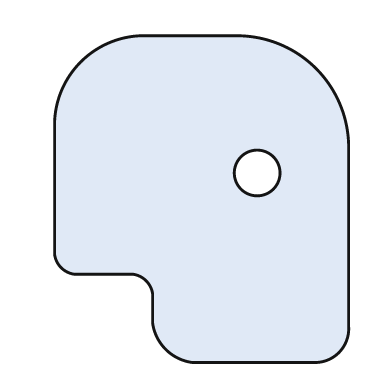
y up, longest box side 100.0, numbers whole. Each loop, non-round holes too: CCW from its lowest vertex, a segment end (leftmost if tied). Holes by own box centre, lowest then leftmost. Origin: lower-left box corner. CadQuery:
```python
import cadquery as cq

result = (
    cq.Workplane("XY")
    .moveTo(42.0, 0.0)
    .lineTo(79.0, 0.0)
    .threePointArc((87.0, 3.0), (90.0, 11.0))
    .lineTo(90.0, 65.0)
    .threePointArc((80.0, 90.0), (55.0, 100.0))
    .lineTo(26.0, 100.0)
    .threePointArc((8.0, 92.0), (0.0, 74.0))
    .lineTo(0.0, 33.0)
    .threePointArc((2.0, 29.0), (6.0, 27.0))
    .lineTo(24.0, 27.0)
    .threePointArc((28.0, 25.0), (30.0, 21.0))
    .lineTo(30.0, 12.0)
    .threePointArc((34.0, 4.0), (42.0, 0.0))
    .close()
    .moveTo(62.0, 58.0)
    .circle(7.0)
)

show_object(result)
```